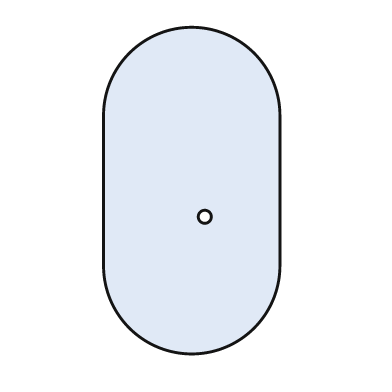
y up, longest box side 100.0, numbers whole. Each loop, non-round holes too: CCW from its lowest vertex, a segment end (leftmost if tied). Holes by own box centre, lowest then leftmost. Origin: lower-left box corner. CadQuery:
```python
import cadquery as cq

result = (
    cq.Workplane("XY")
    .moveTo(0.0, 27.0)
    .threePointArc((27.0, 0.0), (54.0, 27.0))
    .lineTo(54.0, 73.0)
    .threePointArc((27.0, 100.0), (0.0, 73.0))
    .close()
    .moveTo(31.0, 42.0)
    .circle(2.0)
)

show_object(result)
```